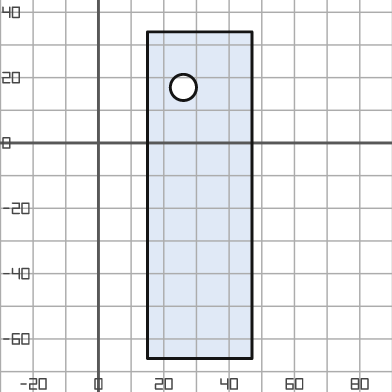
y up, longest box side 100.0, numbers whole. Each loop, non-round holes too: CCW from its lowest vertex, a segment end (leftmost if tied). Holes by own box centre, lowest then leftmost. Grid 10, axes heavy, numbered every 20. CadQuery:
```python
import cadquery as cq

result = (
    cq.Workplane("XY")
    .moveTo(15.0, -66.0)
    .lineTo(47.0, -66.0)
    .lineTo(47.0, 34.0)
    .lineTo(15.0, 34.0)
    .close()
    .moveTo(26.0, 17.0)
    .circle(4.0)
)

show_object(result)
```